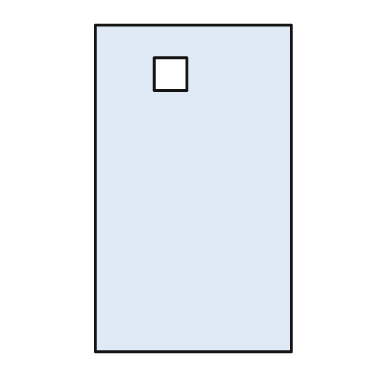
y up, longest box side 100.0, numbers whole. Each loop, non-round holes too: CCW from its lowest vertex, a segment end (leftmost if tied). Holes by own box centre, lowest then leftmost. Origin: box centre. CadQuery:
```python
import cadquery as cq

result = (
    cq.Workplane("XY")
    .moveTo(-30.0, -50.0)
    .lineTo(30.0, -50.0)
    .lineTo(30.0, 50.0)
    .lineTo(-30.0, 50.0)
    .close()
    .moveTo(-12.0, 30.0)
    .lineTo(-2.0, 30.0)
    .lineTo(-2.0, 40.0)
    .lineTo(-12.0, 40.0)
    .close()
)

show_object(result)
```